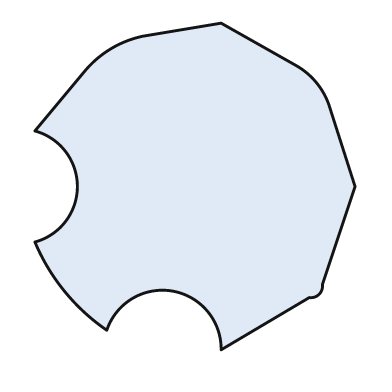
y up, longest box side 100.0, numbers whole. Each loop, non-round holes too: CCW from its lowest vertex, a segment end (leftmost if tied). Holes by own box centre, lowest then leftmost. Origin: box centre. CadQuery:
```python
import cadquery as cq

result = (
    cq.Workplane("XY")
    .moveTo(8.0, -50.0)
    .lineTo(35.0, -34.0)
    .threePointArc((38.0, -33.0), (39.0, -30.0))
    .lineTo(49.0, 0.0)
    .lineTo(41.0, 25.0)
    .threePointArc((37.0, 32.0), (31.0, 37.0))
    .lineTo(8.0, 50.0)
    .lineTo(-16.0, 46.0)
    .threePointArc((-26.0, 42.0), (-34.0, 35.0))
    .lineTo(-49.0, 17.0)
    .threePointArc((-36.0, 0.0), (-49.0, -17.0))
    .threePointArc((-40.0, -32.0), (-27.0, -44.0))
    .threePointArc((-7.0, -32.0), (8.0, -50.0))
    .close()
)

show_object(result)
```